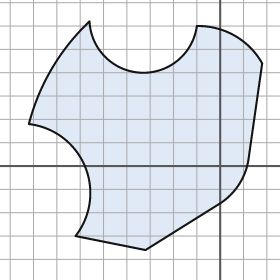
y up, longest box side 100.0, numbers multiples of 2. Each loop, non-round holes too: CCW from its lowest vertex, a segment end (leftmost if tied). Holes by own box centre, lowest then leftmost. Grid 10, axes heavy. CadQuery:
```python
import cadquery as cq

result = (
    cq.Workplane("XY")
    .moveTo(-32.0, -36.0)
    .lineTo(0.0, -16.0)
    .threePointArc((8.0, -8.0), (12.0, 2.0))
    .lineTo(18.0, 44.0)
    .threePointArc((6.0, 56.0), (-10.0, 60.0))
    .threePointArc((-34.0, 40.0), (-56.0, 62.0))
    .threePointArc((-72.0, 42.0), (-82.0, 18.0))
    .threePointArc((-58.0, 0.0), (-62.0, -30.0))
    .close()
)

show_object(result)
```